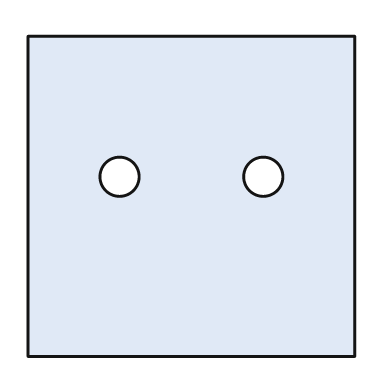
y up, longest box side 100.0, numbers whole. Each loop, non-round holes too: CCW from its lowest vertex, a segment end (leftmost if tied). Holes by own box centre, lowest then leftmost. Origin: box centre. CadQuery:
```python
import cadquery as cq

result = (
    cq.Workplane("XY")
    .moveTo(-50.0, -49.0)
    .lineTo(50.0, -49.0)
    .lineTo(50.0, 49.0)
    .lineTo(-50.0, 49.0)
    .close()
    .moveTo(-22.0, 6.0)
    .circle(6.0)
    .moveTo(22.0, 6.0)
    .circle(6.0)
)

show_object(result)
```